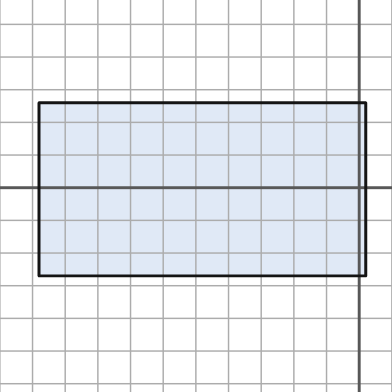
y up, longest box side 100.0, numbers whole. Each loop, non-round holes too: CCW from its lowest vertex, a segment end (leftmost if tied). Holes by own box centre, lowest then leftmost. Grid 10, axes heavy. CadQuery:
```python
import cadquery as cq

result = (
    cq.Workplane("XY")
    .moveTo(-98.0, -27.0)
    .lineTo(2.0, -27.0)
    .lineTo(2.0, 26.0)
    .lineTo(-98.0, 26.0)
    .close()
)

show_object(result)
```